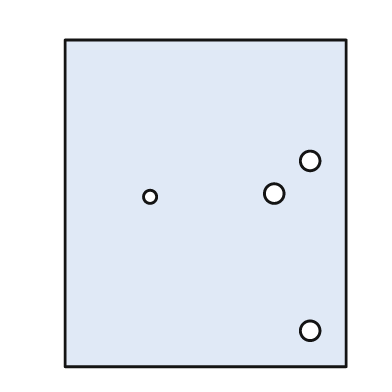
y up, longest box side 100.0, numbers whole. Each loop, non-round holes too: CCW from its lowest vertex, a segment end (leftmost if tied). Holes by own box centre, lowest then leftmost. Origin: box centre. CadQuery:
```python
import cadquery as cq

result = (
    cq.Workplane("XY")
    .moveTo(-43.0, -50.0)
    .lineTo(43.0, -50.0)
    .lineTo(43.0, 50.0)
    .lineTo(-43.0, 50.0)
    .close()
    .moveTo(32.0, -39.0)
    .circle(3.0)
    .moveTo(-17.0, 2.0)
    .circle(2.0)
    .moveTo(21.0, 3.0)
    .circle(3.0)
    .moveTo(32.0, 13.0)
    .circle(3.0)
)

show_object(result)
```